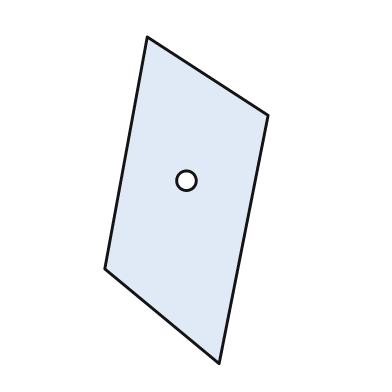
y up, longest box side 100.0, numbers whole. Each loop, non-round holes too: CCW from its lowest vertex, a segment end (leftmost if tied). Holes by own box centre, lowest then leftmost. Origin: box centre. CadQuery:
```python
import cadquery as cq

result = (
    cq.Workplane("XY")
    .moveTo(10.0, -50.0)
    .lineTo(25.0, 26.0)
    .lineTo(-12.0, 50.0)
    .lineTo(-25.0, -21.0)
    .close()
    .moveTo(0.0, 6.0)
    .circle(3.0)
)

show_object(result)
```